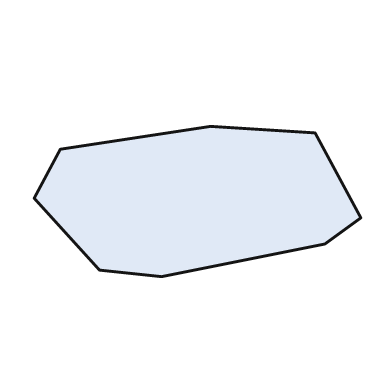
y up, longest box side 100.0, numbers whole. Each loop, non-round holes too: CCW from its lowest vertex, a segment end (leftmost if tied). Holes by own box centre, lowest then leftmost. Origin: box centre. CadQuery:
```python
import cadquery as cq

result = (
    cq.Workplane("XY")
    .moveTo(-11.0, -23.0)
    .lineTo(39.0, -13.0)
    .lineTo(50.0, -5.0)
    .lineTo(36.0, 21.0)
    .lineTo(4.0, 23.0)
    .lineTo(-42.0, 16.0)
    .lineTo(-50.0, 1.0)
    .lineTo(-30.0, -21.0)
    .close()
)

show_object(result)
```